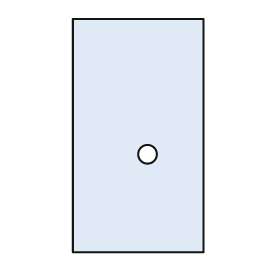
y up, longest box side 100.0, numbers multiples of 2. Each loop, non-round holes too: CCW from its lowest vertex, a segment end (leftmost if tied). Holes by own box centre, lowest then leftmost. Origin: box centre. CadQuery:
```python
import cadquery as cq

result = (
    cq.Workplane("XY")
    .moveTo(-28.0, -50.0)
    .lineTo(28.0, -50.0)
    .lineTo(28.0, 50.0)
    .lineTo(-28.0, 50.0)
    .close()
    .moveTo(4.0, -8.0)
    .circle(4.0)
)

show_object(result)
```